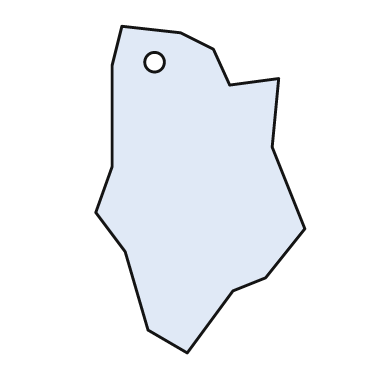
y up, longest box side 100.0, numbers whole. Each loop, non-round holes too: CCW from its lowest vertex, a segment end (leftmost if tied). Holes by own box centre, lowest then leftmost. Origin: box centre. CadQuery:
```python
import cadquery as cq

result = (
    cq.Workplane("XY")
    .moveTo(-4.0, -50.0)
    .lineTo(10.0, -31.0)
    .lineTo(20.0, -27.0)
    .lineTo(32.0, -12.0)
    .lineTo(22.0, 13.0)
    .lineTo(24.0, 34.0)
    .lineTo(9.0, 32.0)
    .lineTo(4.0, 43.0)
    .lineTo(-6.0, 48.0)
    .lineTo(-24.0, 50.0)
    .lineTo(-27.0, 38.0)
    .lineTo(-27.0, 7.0)
    .lineTo(-32.0, -7.0)
    .lineTo(-23.0, -19.0)
    .lineTo(-16.0, -43.0)
    .close()
    .moveTo(-14.0, 39.0)
    .circle(3.0)
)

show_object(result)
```